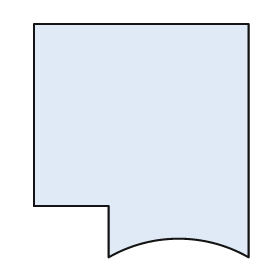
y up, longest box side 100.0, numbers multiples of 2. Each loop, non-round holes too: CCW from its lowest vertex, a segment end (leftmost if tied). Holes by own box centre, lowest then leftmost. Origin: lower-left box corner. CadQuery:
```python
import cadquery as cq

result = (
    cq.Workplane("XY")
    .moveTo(32.0, 0.0)
    .threePointArc((62.0, 8.0), (92.0, 0.0))
    .lineTo(92.0, 100.0)
    .lineTo(0.0, 100.0)
    .lineTo(0.0, 22.0)
    .lineTo(32.0, 22.0)
    .close()
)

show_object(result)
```